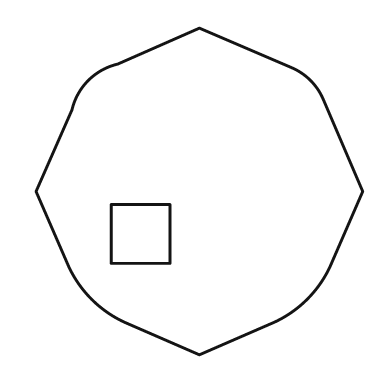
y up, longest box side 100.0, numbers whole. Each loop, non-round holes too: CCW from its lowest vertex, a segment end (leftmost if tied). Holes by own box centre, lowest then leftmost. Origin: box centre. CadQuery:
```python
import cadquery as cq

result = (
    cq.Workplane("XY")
    .moveTo(0.0, -50.0)
    .lineTo(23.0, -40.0)
    .threePointArc((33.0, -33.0), (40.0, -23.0))
    .lineTo(50.0, 0.0)
    .lineTo(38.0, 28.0)
    .threePointArc((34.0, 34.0), (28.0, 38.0))
    .lineTo(0.0, 50.0)
    .lineTo(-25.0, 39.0)
    .threePointArc((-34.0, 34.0), (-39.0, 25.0))
    .lineTo(-50.0, 0.0)
    .lineTo(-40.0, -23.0)
    .threePointArc((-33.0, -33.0), (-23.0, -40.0))
    .close()
    .moveTo(-27.0, -22.0)
    .lineTo(-9.0, -22.0)
    .lineTo(-9.0, -4.0)
    .lineTo(-27.0, -4.0)
    .close()
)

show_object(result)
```